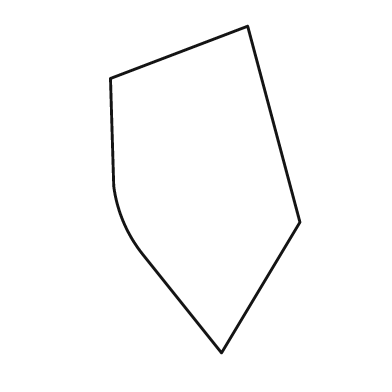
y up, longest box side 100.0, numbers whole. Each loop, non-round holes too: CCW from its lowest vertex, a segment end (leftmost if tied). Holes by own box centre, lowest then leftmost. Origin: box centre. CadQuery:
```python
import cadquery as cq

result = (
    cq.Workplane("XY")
    .moveTo(5.0, -50.0)
    .lineTo(29.0, -10.0)
    .lineTo(13.0, 50.0)
    .lineTo(-29.0, 34.0)
    .lineTo(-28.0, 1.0)
    .threePointArc((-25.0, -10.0), (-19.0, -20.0))
    .close()
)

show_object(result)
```